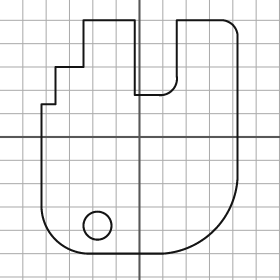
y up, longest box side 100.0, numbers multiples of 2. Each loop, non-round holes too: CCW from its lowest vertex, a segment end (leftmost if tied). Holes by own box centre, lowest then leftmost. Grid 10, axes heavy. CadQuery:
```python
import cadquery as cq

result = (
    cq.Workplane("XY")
    .moveTo(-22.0, -50.0)
    .lineTo(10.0, -50.0)
    .threePointArc((32.0, -40.0), (42.0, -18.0))
    .lineTo(42.0, 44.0)
    .threePointArc((40.0, 48.0), (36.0, 50.0))
    .lineTo(16.0, 50.0)
    .lineTo(16.0, 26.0)
    .threePointArc((14.0, 20.0), (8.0, 18.0))
    .lineTo(-2.0, 18.0)
    .lineTo(-2.0, 50.0)
    .lineTo(-24.0, 50.0)
    .lineTo(-24.0, 30.0)
    .lineTo(-36.0, 30.0)
    .lineTo(-36.0, 14.0)
    .lineTo(-42.0, 14.0)
    .lineTo(-42.0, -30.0)
    .threePointArc((-36.0, -44.0), (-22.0, -50.0))
    .close()
    .moveTo(-18.0, -38.0)
    .circle(6.0)
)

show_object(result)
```